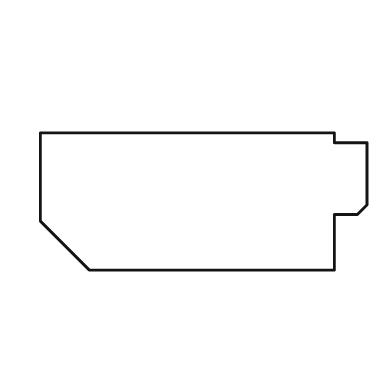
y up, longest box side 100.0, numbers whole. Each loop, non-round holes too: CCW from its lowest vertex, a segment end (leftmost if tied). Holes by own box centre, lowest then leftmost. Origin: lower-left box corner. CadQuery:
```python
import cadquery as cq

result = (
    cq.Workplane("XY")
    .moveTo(15.0, 0.0)
    .lineTo(90.0, 0.0)
    .lineTo(90.0, 17.0)
    .lineTo(97.0, 17.0)
    .lineTo(100.0, 20.0)
    .lineTo(100.0, 39.0)
    .lineTo(90.0, 39.0)
    .lineTo(90.0, 42.0)
    .lineTo(0.0, 42.0)
    .lineTo(0.0, 15.0)
    .close()
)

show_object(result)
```